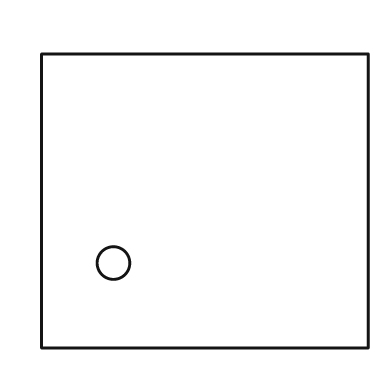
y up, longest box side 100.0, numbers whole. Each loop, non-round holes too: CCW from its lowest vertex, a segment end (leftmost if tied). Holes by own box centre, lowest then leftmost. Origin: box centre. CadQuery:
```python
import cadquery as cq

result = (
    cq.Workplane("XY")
    .moveTo(-50.0, -45.0)
    .lineTo(50.0, -45.0)
    .lineTo(50.0, 45.0)
    .lineTo(-50.0, 45.0)
    .close()
    .moveTo(-28.0, -19.0)
    .circle(5.0)
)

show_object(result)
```